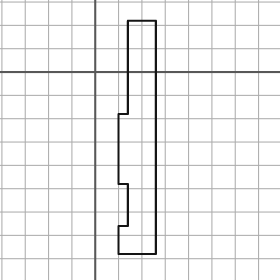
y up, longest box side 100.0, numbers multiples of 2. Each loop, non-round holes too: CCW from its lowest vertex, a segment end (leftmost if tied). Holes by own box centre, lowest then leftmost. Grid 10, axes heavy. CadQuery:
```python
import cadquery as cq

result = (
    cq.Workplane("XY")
    .moveTo(10.0, -78.0)
    .lineTo(26.0, -78.0)
    .lineTo(26.0, 22.0)
    .lineTo(14.0, 22.0)
    .lineTo(14.0, -18.0)
    .lineTo(10.0, -18.0)
    .lineTo(10.0, -48.0)
    .lineTo(14.0, -48.0)
    .lineTo(14.0, -66.0)
    .lineTo(10.0, -66.0)
    .close()
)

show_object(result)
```